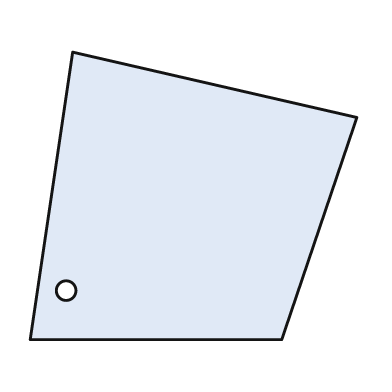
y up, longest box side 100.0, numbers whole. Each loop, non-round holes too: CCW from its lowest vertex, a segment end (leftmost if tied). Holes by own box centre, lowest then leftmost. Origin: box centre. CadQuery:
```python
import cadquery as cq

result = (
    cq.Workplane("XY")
    .moveTo(-50.0, -44.0)
    .lineTo(27.0, -44.0)
    .lineTo(50.0, 24.0)
    .lineTo(-37.0, 44.0)
    .close()
    .moveTo(-39.0, -29.0)
    .circle(3.0)
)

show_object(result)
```